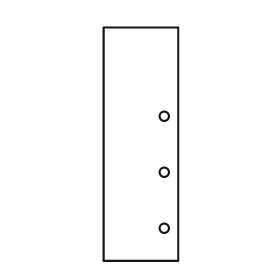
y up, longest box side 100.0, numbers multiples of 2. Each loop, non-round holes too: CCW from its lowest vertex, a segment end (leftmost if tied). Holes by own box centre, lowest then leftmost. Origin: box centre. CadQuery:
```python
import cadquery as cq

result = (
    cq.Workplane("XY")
    .moveTo(-16.0, -50.0)
    .lineTo(16.0, -50.0)
    .lineTo(16.0, 50.0)
    .lineTo(-16.0, 50.0)
    .close()
    .moveTo(10.0, -36.0)
    .circle(2.0)
    .moveTo(10.0, -12.0)
    .circle(2.0)
    .moveTo(10.0, 12.0)
    .circle(2.0)
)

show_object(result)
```